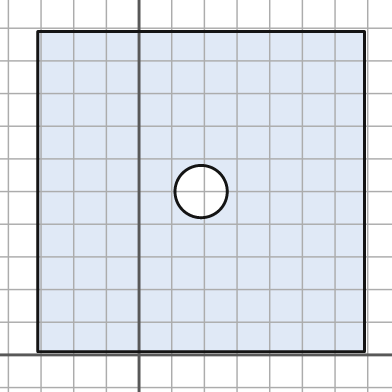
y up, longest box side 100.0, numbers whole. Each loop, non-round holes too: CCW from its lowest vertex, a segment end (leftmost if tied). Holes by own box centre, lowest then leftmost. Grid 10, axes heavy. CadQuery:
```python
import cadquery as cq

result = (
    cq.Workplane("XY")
    .moveTo(-31.0, 1.0)
    .lineTo(69.0, 1.0)
    .lineTo(69.0, 99.0)
    .lineTo(-31.0, 99.0)
    .close()
    .moveTo(19.0, 50.0)
    .circle(8.0)
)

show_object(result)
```